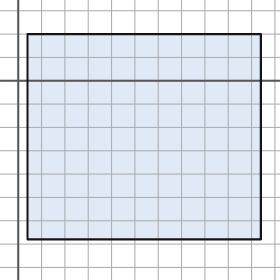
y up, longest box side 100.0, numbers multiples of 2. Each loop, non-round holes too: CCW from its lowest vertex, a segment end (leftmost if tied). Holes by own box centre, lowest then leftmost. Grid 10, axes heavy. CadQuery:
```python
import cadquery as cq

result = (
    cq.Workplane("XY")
    .moveTo(4.0, -68.0)
    .lineTo(104.0, -68.0)
    .lineTo(104.0, 20.0)
    .lineTo(4.0, 20.0)
    .close()
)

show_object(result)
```